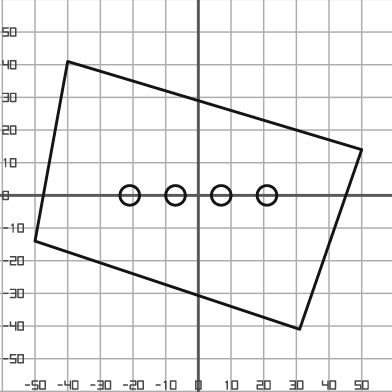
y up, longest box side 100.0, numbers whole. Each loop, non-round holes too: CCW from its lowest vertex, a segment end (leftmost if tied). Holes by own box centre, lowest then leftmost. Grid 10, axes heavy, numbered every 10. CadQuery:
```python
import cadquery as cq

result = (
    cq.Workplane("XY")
    .moveTo(31.0, -41.0)
    .lineTo(50.0, 14.0)
    .lineTo(-40.0, 41.0)
    .lineTo(-50.0, -14.0)
    .close()
    .moveTo(-21.0, 0.0)
    .circle(3.0)
    .moveTo(-7.0, 0.0)
    .circle(3.0)
    .moveTo(7.0, 0.0)
    .circle(3.0)
    .moveTo(21.0, 0.0)
    .circle(3.0)
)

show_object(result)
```